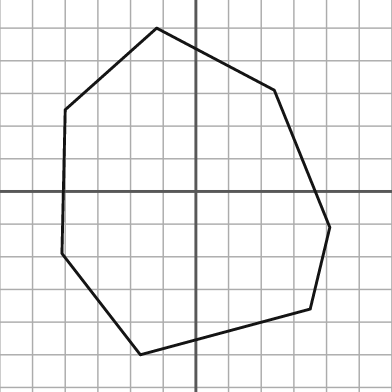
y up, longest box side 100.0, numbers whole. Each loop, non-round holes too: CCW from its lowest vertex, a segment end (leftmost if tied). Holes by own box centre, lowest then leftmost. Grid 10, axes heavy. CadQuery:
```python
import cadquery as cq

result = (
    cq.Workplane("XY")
    .moveTo(-17.0, -50.0)
    .lineTo(35.0, -36.0)
    .lineTo(41.0, -11.0)
    .lineTo(24.0, 31.0)
    .lineTo(-12.0, 50.0)
    .lineTo(-40.0, 25.0)
    .lineTo(-41.0, -19.0)
    .close()
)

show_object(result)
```